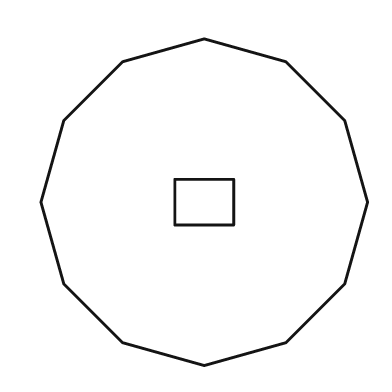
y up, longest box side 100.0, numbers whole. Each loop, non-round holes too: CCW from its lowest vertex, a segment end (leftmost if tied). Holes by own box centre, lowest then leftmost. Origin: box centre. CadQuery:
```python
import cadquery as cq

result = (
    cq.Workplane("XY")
    .moveTo(0.0, -50.0)
    .lineTo(25.0, -43.0)
    .lineTo(43.0, -25.0)
    .lineTo(50.0, 0.0)
    .lineTo(43.0, 25.0)
    .lineTo(25.0, 43.0)
    .lineTo(0.0, 50.0)
    .lineTo(-25.0, 43.0)
    .lineTo(-43.0, 25.0)
    .lineTo(-50.0, 0.0)
    .lineTo(-43.0, -25.0)
    .lineTo(-25.0, -43.0)
    .close()
    .moveTo(-9.0, -7.0)
    .lineTo(9.0, -7.0)
    .lineTo(9.0, 7.0)
    .lineTo(-9.0, 7.0)
    .close()
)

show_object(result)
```